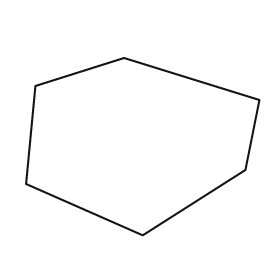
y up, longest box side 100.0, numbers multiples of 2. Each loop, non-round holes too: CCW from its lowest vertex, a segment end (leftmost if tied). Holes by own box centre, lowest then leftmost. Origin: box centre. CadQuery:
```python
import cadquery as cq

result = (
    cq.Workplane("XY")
    .moveTo(0.0, -38.0)
    .lineTo(44.0, -10.0)
    .lineTo(50.0, 20.0)
    .lineTo(-8.0, 38.0)
    .lineTo(-46.0, 26.0)
    .lineTo(-50.0, -16.0)
    .close()
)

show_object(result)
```